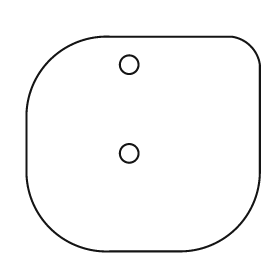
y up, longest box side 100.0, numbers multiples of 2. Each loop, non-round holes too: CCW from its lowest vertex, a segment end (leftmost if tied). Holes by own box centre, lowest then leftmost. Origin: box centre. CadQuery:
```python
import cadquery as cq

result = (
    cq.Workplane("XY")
    .moveTo(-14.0, -46.0)
    .lineTo(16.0, -46.0)
    .threePointArc((40.0, -36.0), (50.0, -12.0))
    .lineTo(50.0, 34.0)
    .threePointArc((46.0, 42.0), (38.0, 46.0))
    .lineTo(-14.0, 46.0)
    .threePointArc((-40.0, 36.0), (-50.0, 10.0))
    .lineTo(-50.0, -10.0)
    .threePointArc((-40.0, -36.0), (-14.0, -46.0))
    .close()
    .moveTo(-6.0, -4.0)
    .circle(4.0)
    .moveTo(-6.0, 34.0)
    .circle(4.0)
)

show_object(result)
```